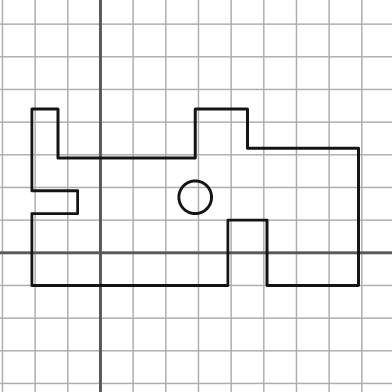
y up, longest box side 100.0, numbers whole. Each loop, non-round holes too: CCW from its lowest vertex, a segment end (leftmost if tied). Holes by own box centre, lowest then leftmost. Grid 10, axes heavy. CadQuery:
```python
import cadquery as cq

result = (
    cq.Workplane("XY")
    .moveTo(-21.0, -10.0)
    .lineTo(39.0, -10.0)
    .lineTo(39.0, 10.0)
    .lineTo(51.0, 10.0)
    .lineTo(51.0, -10.0)
    .lineTo(79.0, -10.0)
    .lineTo(79.0, 32.0)
    .lineTo(45.0, 32.0)
    .lineTo(45.0, 44.0)
    .lineTo(29.0, 44.0)
    .lineTo(29.0, 29.0)
    .lineTo(-13.0, 29.0)
    .lineTo(-13.0, 44.0)
    .lineTo(-21.0, 44.0)
    .lineTo(-21.0, 19.0)
    .lineTo(-7.0, 19.0)
    .lineTo(-7.0, 12.0)
    .lineTo(-21.0, 12.0)
    .close()
    .moveTo(29.0, 17.0)
    .circle(5.0)
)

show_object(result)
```